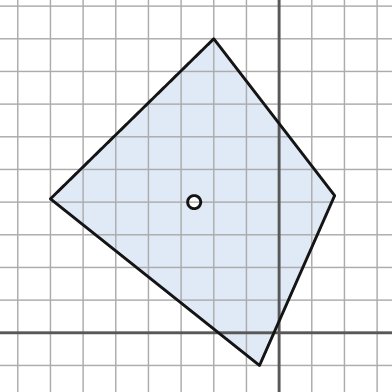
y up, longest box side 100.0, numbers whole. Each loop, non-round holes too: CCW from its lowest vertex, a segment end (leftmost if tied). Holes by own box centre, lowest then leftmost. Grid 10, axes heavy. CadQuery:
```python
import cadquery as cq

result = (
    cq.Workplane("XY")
    .moveTo(-6.0, -10.0)
    .lineTo(17.0, 42.0)
    .lineTo(-20.0, 90.0)
    .lineTo(-70.0, 41.0)
    .close()
    .moveTo(-26.0, 40.0)
    .circle(2.0)
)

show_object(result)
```